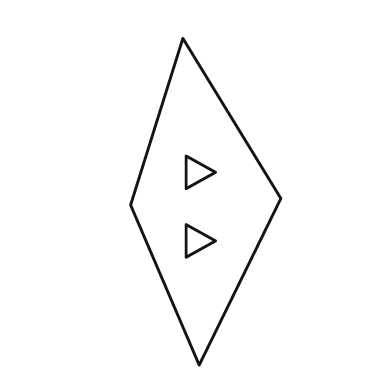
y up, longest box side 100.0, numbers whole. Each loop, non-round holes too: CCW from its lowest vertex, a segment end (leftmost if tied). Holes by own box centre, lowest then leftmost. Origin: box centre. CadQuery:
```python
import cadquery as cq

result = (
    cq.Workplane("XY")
    .moveTo(-2.0, -50.0)
    .lineTo(23.0, 1.0)
    .lineTo(-7.0, 50.0)
    .lineTo(-23.0, -1.0)
    .close()
    .moveTo(-6.0, -17.0)
    .lineTo(3.0, -12.0)
    .lineTo(-6.0, -7.0)
    .close()
    .moveTo(-6.0, 4.0)
    .lineTo(3.0, 9.0)
    .lineTo(-6.0, 14.0)
    .close()
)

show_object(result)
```